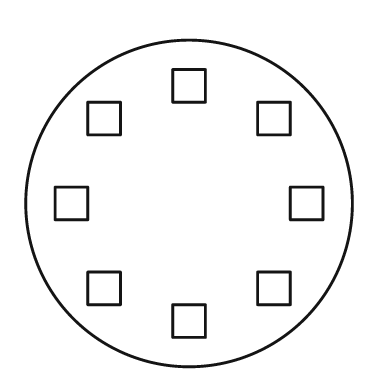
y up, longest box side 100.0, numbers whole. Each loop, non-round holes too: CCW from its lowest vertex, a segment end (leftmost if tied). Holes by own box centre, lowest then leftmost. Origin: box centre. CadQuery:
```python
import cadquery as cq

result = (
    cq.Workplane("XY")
    .moveTo(0.0, 0.0)
    .circle(50.0)
    .moveTo(-5.0, -41.0)
    .lineTo(5.0, -41.0)
    .lineTo(5.0, -31.0)
    .lineTo(-5.0, -31.0)
    .close()
    .moveTo(-31.0, -31.0)
    .lineTo(-21.0, -31.0)
    .lineTo(-21.0, -21.0)
    .lineTo(-31.0, -21.0)
    .close()
    .moveTo(21.0, -31.0)
    .lineTo(31.0, -31.0)
    .lineTo(31.0, -21.0)
    .lineTo(21.0, -21.0)
    .close()
    .moveTo(-41.0, -5.0)
    .lineTo(-31.0, -5.0)
    .lineTo(-31.0, 5.0)
    .lineTo(-41.0, 5.0)
    .close()
    .moveTo(31.0, -5.0)
    .lineTo(41.0, -5.0)
    .lineTo(41.0, 5.0)
    .lineTo(31.0, 5.0)
    .close()
    .moveTo(-31.0, 21.0)
    .lineTo(-21.0, 21.0)
    .lineTo(-21.0, 31.0)
    .lineTo(-31.0, 31.0)
    .close()
    .moveTo(21.0, 21.0)
    .lineTo(31.0, 21.0)
    .lineTo(31.0, 31.0)
    .lineTo(21.0, 31.0)
    .close()
    .moveTo(-5.0, 31.0)
    .lineTo(5.0, 31.0)
    .lineTo(5.0, 41.0)
    .lineTo(-5.0, 41.0)
    .close()
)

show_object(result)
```